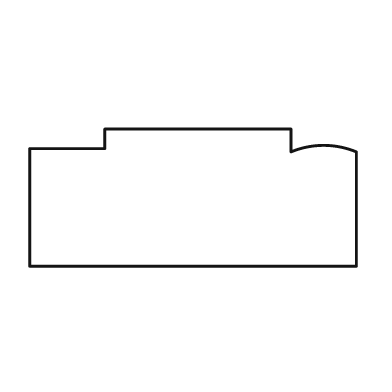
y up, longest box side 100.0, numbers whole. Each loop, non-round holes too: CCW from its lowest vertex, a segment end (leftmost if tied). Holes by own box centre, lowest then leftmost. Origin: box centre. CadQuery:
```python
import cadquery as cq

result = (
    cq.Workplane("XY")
    .moveTo(-50.0, -21.0)
    .lineTo(50.0, -21.0)
    .lineTo(50.0, 14.0)
    .threePointArc((40.0, 16.0), (30.0, 14.0))
    .lineTo(30.0, 21.0)
    .lineTo(-27.0, 21.0)
    .lineTo(-27.0, 15.0)
    .lineTo(-50.0, 15.0)
    .close()
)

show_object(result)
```